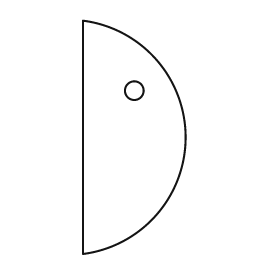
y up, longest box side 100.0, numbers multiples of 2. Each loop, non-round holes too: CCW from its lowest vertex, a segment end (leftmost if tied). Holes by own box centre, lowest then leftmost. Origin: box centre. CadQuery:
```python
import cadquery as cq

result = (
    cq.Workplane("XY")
    .moveTo(-22.0, -50.0)
    .threePointArc((22.0, 0.0), (-22.0, 50.0))
    .close()
    .moveTo(0.0, 20.0)
    .circle(4.0)
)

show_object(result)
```